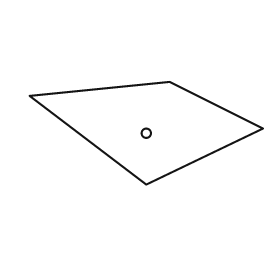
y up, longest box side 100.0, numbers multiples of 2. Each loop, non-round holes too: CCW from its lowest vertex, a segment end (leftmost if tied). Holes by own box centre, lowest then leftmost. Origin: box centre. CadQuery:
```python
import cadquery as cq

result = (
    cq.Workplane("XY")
    .moveTo(0.0, -22.0)
    .lineTo(50.0, 2.0)
    .lineTo(10.0, 22.0)
    .lineTo(-50.0, 16.0)
    .close()
    .moveTo(0.0, 0.0)
    .circle(2.0)
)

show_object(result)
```